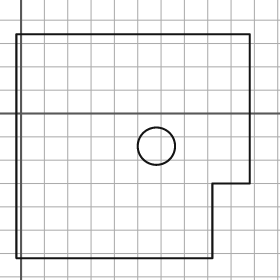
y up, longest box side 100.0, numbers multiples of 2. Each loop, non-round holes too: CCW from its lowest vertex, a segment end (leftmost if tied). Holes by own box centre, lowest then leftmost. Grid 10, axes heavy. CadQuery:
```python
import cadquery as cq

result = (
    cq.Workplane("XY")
    .moveTo(-2.0, -62.0)
    .lineTo(82.0, -62.0)
    .lineTo(82.0, -30.0)
    .lineTo(98.0, -30.0)
    .lineTo(98.0, 34.0)
    .lineTo(-2.0, 34.0)
    .close()
    .moveTo(58.0, -14.0)
    .circle(8.0)
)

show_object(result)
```